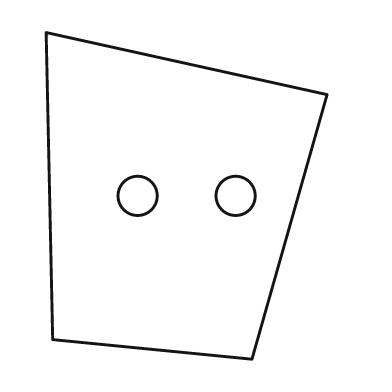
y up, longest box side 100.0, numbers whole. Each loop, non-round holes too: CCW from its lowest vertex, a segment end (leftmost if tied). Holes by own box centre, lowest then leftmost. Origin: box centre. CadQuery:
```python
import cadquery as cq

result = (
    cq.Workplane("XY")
    .moveTo(20.0, -50.0)
    .lineTo(43.0, 31.0)
    .lineTo(-43.0, 50.0)
    .lineTo(-41.0, -44.0)
    .close()
    .moveTo(-15.0, 0.0)
    .circle(6.0)
    .moveTo(15.0, 0.0)
    .circle(6.0)
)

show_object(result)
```